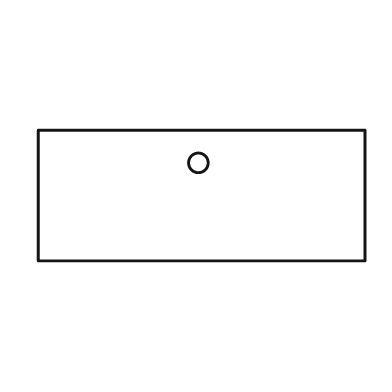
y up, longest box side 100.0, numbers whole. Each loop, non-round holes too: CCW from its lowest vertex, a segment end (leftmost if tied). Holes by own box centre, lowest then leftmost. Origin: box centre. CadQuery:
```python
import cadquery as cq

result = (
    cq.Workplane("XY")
    .moveTo(-50.0, -20.0)
    .lineTo(50.0, -20.0)
    .lineTo(50.0, 20.0)
    .lineTo(-50.0, 20.0)
    .close()
    .moveTo(-1.0, 10.0)
    .circle(3.0)
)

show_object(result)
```